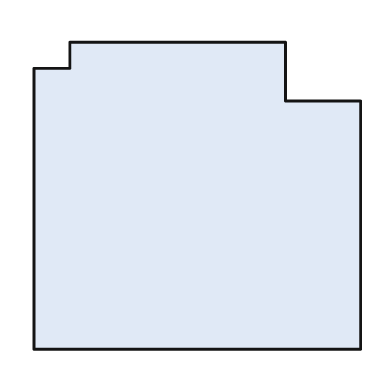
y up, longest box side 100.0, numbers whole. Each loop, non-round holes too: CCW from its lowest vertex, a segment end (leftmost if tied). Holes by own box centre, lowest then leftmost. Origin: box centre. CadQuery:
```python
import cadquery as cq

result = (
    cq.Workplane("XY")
    .moveTo(-50.0, -47.0)
    .lineTo(50.0, -47.0)
    .lineTo(50.0, 29.0)
    .lineTo(27.0, 29.0)
    .lineTo(27.0, 47.0)
    .lineTo(-39.0, 47.0)
    .lineTo(-39.0, 39.0)
    .lineTo(-50.0, 39.0)
    .close()
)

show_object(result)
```